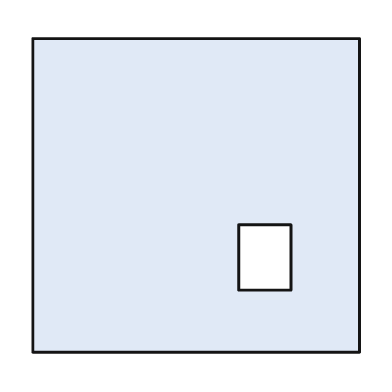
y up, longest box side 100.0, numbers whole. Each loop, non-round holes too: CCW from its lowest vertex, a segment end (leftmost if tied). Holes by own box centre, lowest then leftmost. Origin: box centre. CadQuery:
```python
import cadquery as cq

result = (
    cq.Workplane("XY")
    .moveTo(-50.0, -48.0)
    .lineTo(50.0, -48.0)
    .lineTo(50.0, 48.0)
    .lineTo(-50.0, 48.0)
    .close()
    .moveTo(13.0, -29.0)
    .lineTo(29.0, -29.0)
    .lineTo(29.0, -9.0)
    .lineTo(13.0, -9.0)
    .close()
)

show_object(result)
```